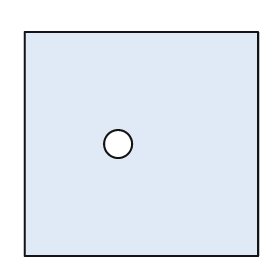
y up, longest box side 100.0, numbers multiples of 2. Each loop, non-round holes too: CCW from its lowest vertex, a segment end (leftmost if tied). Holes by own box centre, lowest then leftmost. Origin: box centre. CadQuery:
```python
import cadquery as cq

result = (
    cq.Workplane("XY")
    .moveTo(-50.0, -48.0)
    .lineTo(50.0, -48.0)
    .lineTo(50.0, 48.0)
    .lineTo(-50.0, 48.0)
    .close()
    .moveTo(-10.0, 0.0)
    .circle(6.0)
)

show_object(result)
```